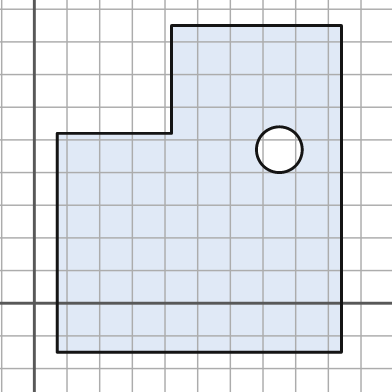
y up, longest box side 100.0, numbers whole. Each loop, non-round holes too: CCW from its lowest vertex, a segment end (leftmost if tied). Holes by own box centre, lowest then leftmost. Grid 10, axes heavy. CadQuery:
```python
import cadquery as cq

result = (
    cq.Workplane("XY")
    .moveTo(7.0, -15.0)
    .lineTo(94.0, -15.0)
    .lineTo(94.0, 85.0)
    .lineTo(42.0, 85.0)
    .lineTo(42.0, 52.0)
    .lineTo(7.0, 52.0)
    .close()
    .moveTo(75.0, 47.0)
    .circle(7.0)
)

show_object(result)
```